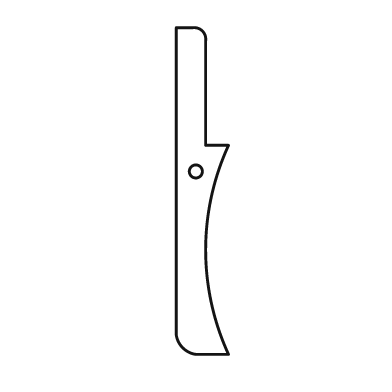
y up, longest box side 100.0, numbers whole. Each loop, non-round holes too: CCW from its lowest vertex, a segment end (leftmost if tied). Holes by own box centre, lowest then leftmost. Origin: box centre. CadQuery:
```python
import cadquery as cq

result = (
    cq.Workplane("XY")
    .moveTo(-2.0, -50.0)
    .lineTo(8.0, -50.0)
    .threePointArc((1.0, -18.0), (8.0, 14.0))
    .lineTo(1.0, 14.0)
    .lineTo(1.0, 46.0)
    .threePointArc((0.0, 49.0), (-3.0, 50.0))
    .lineTo(-8.0, 50.0)
    .lineTo(-8.0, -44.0)
    .threePointArc((-6.0, -48.0), (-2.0, -50.0))
    .close()
    .moveTo(-2.0, 6.0)
    .circle(2.0)
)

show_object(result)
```